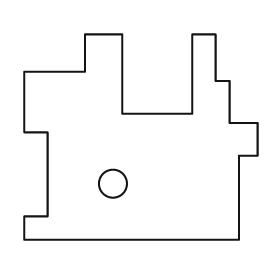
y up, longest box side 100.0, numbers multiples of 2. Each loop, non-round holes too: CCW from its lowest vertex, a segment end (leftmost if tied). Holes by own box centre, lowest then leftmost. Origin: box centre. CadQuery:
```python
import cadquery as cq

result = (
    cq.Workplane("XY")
    .moveTo(-50.0, -44.0)
    .lineTo(42.0, -44.0)
    .lineTo(42.0, -8.0)
    .lineTo(50.0, -8.0)
    .lineTo(50.0, 6.0)
    .lineTo(38.0, 6.0)
    .lineTo(38.0, 24.0)
    .lineTo(32.0, 24.0)
    .lineTo(32.0, 44.0)
    .lineTo(22.0, 44.0)
    .lineTo(22.0, 10.0)
    .lineTo(-8.0, 10.0)
    .lineTo(-8.0, 44.0)
    .lineTo(-24.0, 44.0)
    .lineTo(-24.0, 28.0)
    .lineTo(-50.0, 28.0)
    .lineTo(-50.0, 2.0)
    .lineTo(-40.0, 2.0)
    .lineTo(-40.0, -34.0)
    .lineTo(-50.0, -34.0)
    .close()
    .moveTo(-12.0, -20.0)
    .circle(6.0)
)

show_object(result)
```